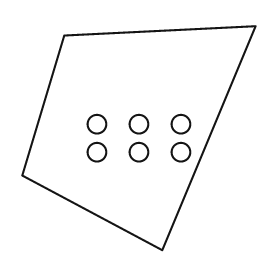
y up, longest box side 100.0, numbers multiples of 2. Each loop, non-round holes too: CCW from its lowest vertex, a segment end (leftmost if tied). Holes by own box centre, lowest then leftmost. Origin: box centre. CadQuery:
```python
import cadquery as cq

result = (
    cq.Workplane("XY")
    .moveTo(10.0, -48.0)
    .lineTo(50.0, 48.0)
    .lineTo(-32.0, 44.0)
    .lineTo(-50.0, -16.0)
    .close()
    .moveTo(-18.0, -6.0)
    .circle(4.0)
    .moveTo(0.0, -6.0)
    .circle(4.0)
    .moveTo(18.0, -6.0)
    .circle(4.0)
    .moveTo(-18.0, 6.0)
    .circle(4.0)
    .moveTo(0.0, 6.0)
    .circle(4.0)
    .moveTo(18.0, 6.0)
    .circle(4.0)
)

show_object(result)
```